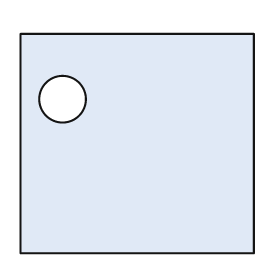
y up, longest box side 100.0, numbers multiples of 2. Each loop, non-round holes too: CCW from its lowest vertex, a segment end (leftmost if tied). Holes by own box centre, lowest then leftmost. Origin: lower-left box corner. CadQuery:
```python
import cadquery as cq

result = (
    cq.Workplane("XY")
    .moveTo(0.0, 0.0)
    .lineTo(100.0, 0.0)
    .lineTo(100.0, 94.0)
    .lineTo(0.0, 94.0)
    .close()
    .moveTo(18.0, 66.0)
    .circle(10.0)
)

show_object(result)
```